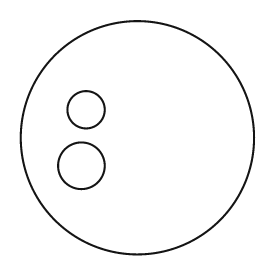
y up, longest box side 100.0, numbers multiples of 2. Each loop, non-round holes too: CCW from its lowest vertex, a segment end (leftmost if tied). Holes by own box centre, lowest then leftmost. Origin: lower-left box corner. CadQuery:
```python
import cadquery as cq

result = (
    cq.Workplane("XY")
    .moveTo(50.0, 50.0)
    .circle(50.0)
    .moveTo(26.0, 38.0)
    .circle(10.0)
    .moveTo(28.0, 62.0)
    .circle(8.0)
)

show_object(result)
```